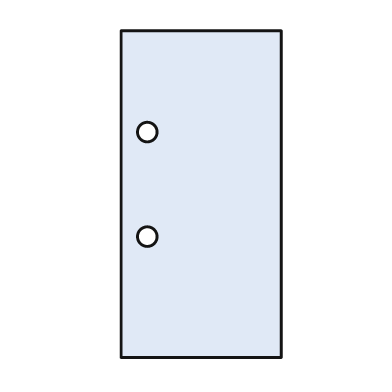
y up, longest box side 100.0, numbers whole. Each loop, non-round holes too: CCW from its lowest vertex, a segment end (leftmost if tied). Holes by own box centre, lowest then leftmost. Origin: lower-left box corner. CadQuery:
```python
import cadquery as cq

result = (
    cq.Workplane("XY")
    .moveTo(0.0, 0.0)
    .lineTo(49.0, 0.0)
    .lineTo(49.0, 100.0)
    .lineTo(0.0, 100.0)
    .close()
    .moveTo(8.0, 37.0)
    .circle(3.0)
    .moveTo(8.0, 69.0)
    .circle(3.0)
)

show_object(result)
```